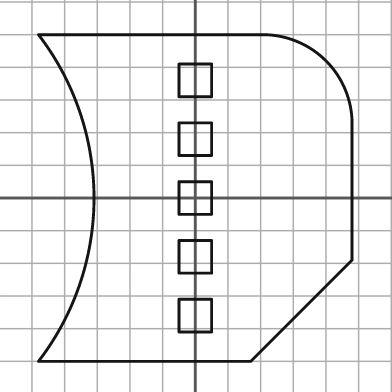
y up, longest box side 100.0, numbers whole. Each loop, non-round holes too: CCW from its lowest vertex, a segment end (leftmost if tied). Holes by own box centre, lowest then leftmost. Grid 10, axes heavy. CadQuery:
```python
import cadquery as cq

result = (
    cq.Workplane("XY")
    .moveTo(-48.0, -50.0)
    .lineTo(17.0, -50.0)
    .lineTo(48.0, -19.0)
    .lineTo(48.0, 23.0)
    .threePointArc((40.0, 42.0), (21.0, 50.0))
    .lineTo(-48.0, 50.0)
    .threePointArc((-31.0, 0.0), (-48.0, -50.0))
    .close()
    .moveTo(-5.0, -41.0)
    .lineTo(5.0, -41.0)
    .lineTo(5.0, -31.0)
    .lineTo(-5.0, -31.0)
    .close()
    .moveTo(-5.0, -23.0)
    .lineTo(5.0, -23.0)
    .lineTo(5.0, -13.0)
    .lineTo(-5.0, -13.0)
    .close()
    .moveTo(-5.0, -5.0)
    .lineTo(5.0, -5.0)
    .lineTo(5.0, 5.0)
    .lineTo(-5.0, 5.0)
    .close()
    .moveTo(-5.0, 13.0)
    .lineTo(5.0, 13.0)
    .lineTo(5.0, 23.0)
    .lineTo(-5.0, 23.0)
    .close()
    .moveTo(-5.0, 31.0)
    .lineTo(5.0, 31.0)
    .lineTo(5.0, 41.0)
    .lineTo(-5.0, 41.0)
    .close()
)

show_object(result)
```